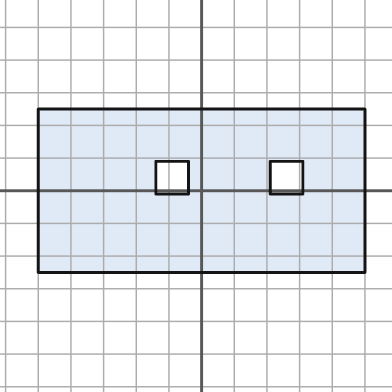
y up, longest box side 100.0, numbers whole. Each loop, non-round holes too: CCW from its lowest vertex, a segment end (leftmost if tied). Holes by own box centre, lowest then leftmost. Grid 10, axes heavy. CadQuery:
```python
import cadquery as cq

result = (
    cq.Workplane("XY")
    .moveTo(-50.0, -25.0)
    .lineTo(50.0, -25.0)
    .lineTo(50.0, 25.0)
    .lineTo(-50.0, 25.0)
    .close()
    .moveTo(-14.0, -1.0)
    .lineTo(-4.0, -1.0)
    .lineTo(-4.0, 9.0)
    .lineTo(-14.0, 9.0)
    .close()
    .moveTo(21.0, -1.0)
    .lineTo(31.0, -1.0)
    .lineTo(31.0, 9.0)
    .lineTo(21.0, 9.0)
    .close()
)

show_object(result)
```